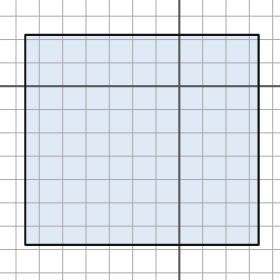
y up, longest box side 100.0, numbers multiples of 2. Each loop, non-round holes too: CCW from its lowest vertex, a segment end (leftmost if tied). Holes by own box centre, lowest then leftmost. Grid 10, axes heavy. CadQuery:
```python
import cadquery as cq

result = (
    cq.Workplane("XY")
    .moveTo(-66.0, -68.0)
    .lineTo(34.0, -68.0)
    .lineTo(34.0, 22.0)
    .lineTo(-66.0, 22.0)
    .close()
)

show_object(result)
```